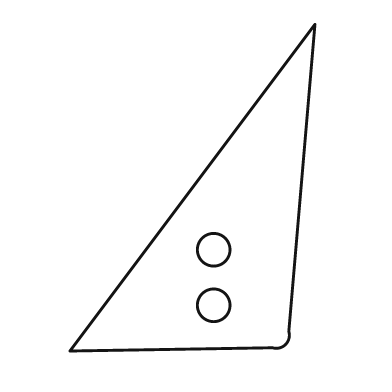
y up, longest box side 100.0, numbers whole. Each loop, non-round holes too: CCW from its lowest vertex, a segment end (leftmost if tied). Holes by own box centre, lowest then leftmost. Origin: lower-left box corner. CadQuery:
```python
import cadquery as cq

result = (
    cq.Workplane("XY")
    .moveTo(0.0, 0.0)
    .lineTo(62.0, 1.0)
    .threePointArc((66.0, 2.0), (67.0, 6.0))
    .lineTo(75.0, 100.0)
    .close()
    .moveTo(44.0, 14.0)
    .circle(5.0)
    .moveTo(44.0, 31.0)
    .circle(5.0)
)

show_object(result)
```